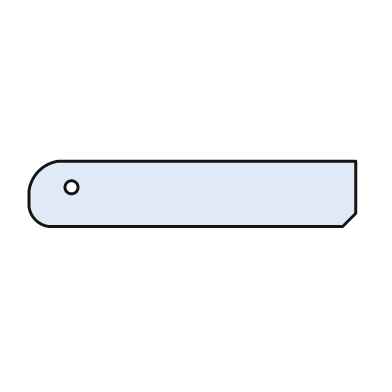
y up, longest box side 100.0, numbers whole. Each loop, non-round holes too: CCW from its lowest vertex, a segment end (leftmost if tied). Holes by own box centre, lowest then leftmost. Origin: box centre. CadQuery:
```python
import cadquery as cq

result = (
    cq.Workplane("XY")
    .moveTo(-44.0, -10.0)
    .lineTo(46.0, -10.0)
    .lineTo(50.0, -6.0)
    .lineTo(50.0, 10.0)
    .lineTo(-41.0, 10.0)
    .threePointArc((-47.0, 7.0), (-50.0, 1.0))
    .lineTo(-50.0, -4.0)
    .threePointArc((-48.0, -8.0), (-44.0, -10.0))
    .close()
    .moveTo(-37.0, 2.0)
    .circle(2.0)
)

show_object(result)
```